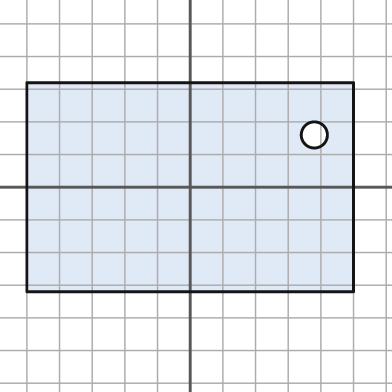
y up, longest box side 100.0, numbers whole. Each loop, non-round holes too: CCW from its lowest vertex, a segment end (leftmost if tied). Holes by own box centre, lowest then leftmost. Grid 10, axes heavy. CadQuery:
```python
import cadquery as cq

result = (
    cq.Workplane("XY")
    .moveTo(-50.0, -32.0)
    .lineTo(50.0, -32.0)
    .lineTo(50.0, 32.0)
    .lineTo(-50.0, 32.0)
    .close()
    .moveTo(38.0, 16.0)
    .circle(4.0)
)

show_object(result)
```